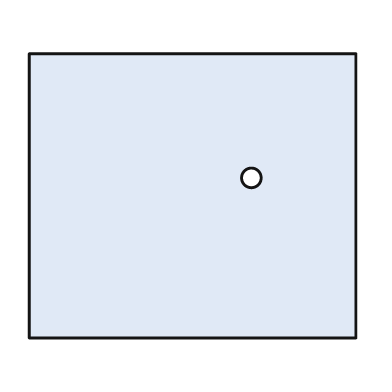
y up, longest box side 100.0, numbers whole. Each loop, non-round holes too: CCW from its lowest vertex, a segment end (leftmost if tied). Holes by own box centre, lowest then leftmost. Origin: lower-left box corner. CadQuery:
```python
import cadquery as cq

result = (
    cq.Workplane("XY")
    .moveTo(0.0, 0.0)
    .lineTo(100.0, 0.0)
    .lineTo(100.0, 87.0)
    .lineTo(0.0, 87.0)
    .close()
    .moveTo(68.0, 49.0)
    .circle(3.0)
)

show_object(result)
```